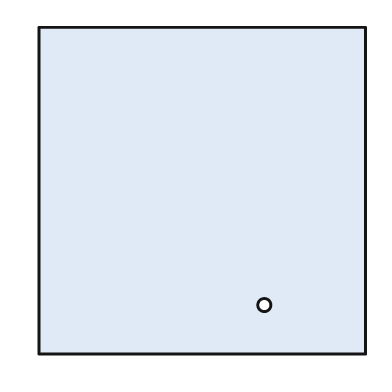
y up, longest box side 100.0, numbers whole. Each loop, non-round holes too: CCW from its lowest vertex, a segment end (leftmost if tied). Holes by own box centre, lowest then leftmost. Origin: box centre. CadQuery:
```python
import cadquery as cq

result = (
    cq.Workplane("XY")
    .moveTo(-50.0, -50.0)
    .lineTo(50.0, -50.0)
    .lineTo(50.0, 50.0)
    .lineTo(-50.0, 50.0)
    .close()
    .moveTo(19.0, -35.0)
    .circle(2.0)
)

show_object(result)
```